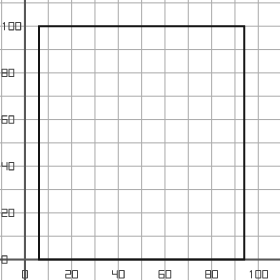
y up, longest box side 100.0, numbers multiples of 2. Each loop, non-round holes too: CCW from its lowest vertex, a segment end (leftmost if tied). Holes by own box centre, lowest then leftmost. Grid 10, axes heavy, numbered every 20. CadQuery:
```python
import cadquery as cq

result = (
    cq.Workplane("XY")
    .moveTo(6.0, 0.0)
    .lineTo(94.0, 0.0)
    .lineTo(94.0, 100.0)
    .lineTo(6.0, 100.0)
    .close()
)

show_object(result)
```